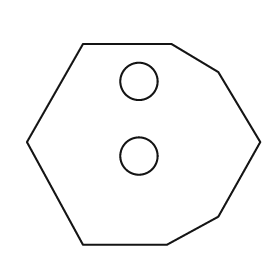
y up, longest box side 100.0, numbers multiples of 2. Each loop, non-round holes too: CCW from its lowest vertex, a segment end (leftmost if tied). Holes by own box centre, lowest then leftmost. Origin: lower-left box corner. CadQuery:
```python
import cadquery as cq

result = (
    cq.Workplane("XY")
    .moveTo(24.0, 0.0)
    .lineTo(60.0, 0.0)
    .lineTo(82.0, 12.0)
    .lineTo(100.0, 44.0)
    .lineTo(82.0, 74.0)
    .lineTo(62.0, 86.0)
    .lineTo(24.0, 86.0)
    .lineTo(0.0, 44.0)
    .close()
    .moveTo(48.0, 38.0)
    .circle(8.0)
    .moveTo(48.0, 70.0)
    .circle(8.0)
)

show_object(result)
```